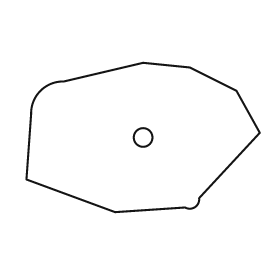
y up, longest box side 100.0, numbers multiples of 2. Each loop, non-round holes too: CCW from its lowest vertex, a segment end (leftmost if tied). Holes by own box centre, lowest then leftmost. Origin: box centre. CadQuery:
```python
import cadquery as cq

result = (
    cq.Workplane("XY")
    .moveTo(-12.0, -32.0)
    .lineTo(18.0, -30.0)
    .threePointArc((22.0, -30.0), (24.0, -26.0))
    .lineTo(50.0, 2.0)
    .lineTo(40.0, 20.0)
    .lineTo(20.0, 30.0)
    .lineTo(0.0, 32.0)
    .lineTo(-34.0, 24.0)
    .threePointArc((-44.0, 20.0), (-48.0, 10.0))
    .lineTo(-50.0, -18.0)
    .close()
    .moveTo(0.0, 0.0)
    .circle(4.0)
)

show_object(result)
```